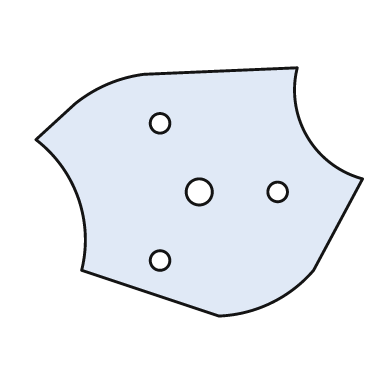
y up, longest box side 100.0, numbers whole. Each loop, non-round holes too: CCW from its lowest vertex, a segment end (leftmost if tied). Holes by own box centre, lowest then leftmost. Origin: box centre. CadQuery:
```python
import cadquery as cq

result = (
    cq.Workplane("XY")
    .moveTo(6.0, -38.0)
    .threePointArc((22.0, -34.0), (35.0, -24.0))
    .lineTo(50.0, 4.0)
    .threePointArc((33.0, 17.0), (30.0, 38.0))
    .lineTo(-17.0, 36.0)
    .threePointArc((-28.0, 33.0), (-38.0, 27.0))
    .lineTo(-50.0, 16.0)
    .threePointArc((-37.0, -2.0), (-36.0, -24.0))
    .close()
    .moveTo(-12.0, -21.0)
    .circle(3.0)
    .moveTo(0.0, 0.0)
    .circle(4.0)
    .moveTo(24.0, 0.0)
    .circle(3.0)
    .moveTo(-12.0, 21.0)
    .circle(3.0)
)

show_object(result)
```